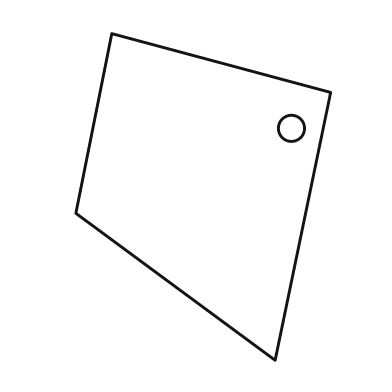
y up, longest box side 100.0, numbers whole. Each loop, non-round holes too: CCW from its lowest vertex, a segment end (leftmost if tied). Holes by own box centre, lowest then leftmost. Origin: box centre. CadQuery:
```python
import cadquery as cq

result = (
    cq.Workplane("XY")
    .moveTo(22.0, -50.0)
    .lineTo(39.0, 32.0)
    .lineTo(-28.0, 50.0)
    .lineTo(-39.0, -5.0)
    .close()
    .moveTo(27.0, 21.0)
    .circle(4.0)
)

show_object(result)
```